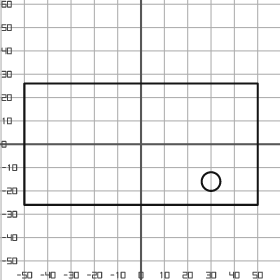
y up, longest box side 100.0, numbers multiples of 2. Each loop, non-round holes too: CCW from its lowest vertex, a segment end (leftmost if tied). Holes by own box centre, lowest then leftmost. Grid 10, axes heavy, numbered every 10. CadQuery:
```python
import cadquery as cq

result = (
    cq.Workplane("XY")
    .moveTo(-50.0, -26.0)
    .lineTo(50.0, -26.0)
    .lineTo(50.0, 26.0)
    .lineTo(-50.0, 26.0)
    .close()
    .moveTo(30.0, -16.0)
    .circle(4.0)
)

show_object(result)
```